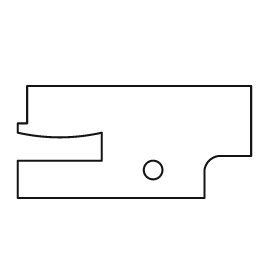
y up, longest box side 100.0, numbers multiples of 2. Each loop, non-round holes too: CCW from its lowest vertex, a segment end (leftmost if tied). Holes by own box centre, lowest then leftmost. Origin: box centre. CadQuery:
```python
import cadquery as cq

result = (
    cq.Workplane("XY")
    .moveTo(-50.0, -24.0)
    .lineTo(30.0, -24.0)
    .lineTo(30.0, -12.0)
    .threePointArc((32.0, -8.0), (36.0, -6.0))
    .lineTo(50.0, -6.0)
    .lineTo(50.0, 24.0)
    .lineTo(-46.0, 24.0)
    .lineTo(-46.0, 8.0)
    .lineTo(-50.0, 8.0)
    .lineTo(-50.0, 4.0)
    .threePointArc((-32.0, 2.0), (-14.0, 4.0))
    .lineTo(-14.0, -8.0)
    .lineTo(-50.0, -8.0)
    .close()
    .moveTo(8.0, -12.0)
    .circle(4.0)
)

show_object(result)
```